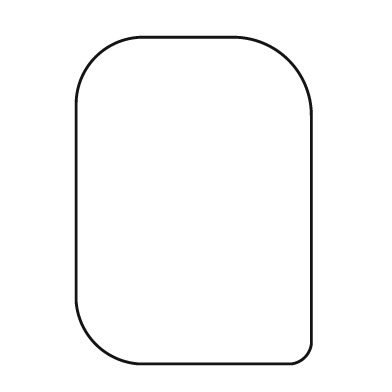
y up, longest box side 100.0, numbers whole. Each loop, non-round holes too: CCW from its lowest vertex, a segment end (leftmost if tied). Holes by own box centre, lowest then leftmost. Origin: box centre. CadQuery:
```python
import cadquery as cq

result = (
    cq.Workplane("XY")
    .moveTo(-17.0, -50.0)
    .lineTo(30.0, -50.0)
    .threePointArc((34.0, -48.0), (36.0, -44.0))
    .lineTo(36.0, 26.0)
    .threePointArc((29.0, 43.0), (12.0, 50.0))
    .lineTo(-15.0, 50.0)
    .threePointArc((-30.0, 44.0), (-36.0, 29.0))
    .lineTo(-36.0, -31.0)
    .threePointArc((-30.0, -44.0), (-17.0, -50.0))
    .close()
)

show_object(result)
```